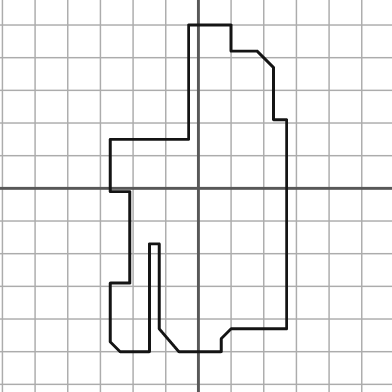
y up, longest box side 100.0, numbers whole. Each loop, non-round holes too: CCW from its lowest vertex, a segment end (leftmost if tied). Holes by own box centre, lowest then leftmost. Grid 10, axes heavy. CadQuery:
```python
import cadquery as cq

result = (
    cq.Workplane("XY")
    .moveTo(-24.0, -50.0)
    .lineTo(-15.0, -50.0)
    .lineTo(-15.0, -17.0)
    .lineTo(-12.0, -17.0)
    .lineTo(-12.0, -43.0)
    .lineTo(-6.0, -50.0)
    .lineTo(7.0, -50.0)
    .lineTo(7.0, -46.0)
    .lineTo(10.0, -43.0)
    .lineTo(27.0, -43.0)
    .lineTo(27.0, 21.0)
    .lineTo(23.0, 21.0)
    .lineTo(23.0, 37.0)
    .lineTo(18.0, 42.0)
    .lineTo(10.0, 42.0)
    .lineTo(10.0, 50.0)
    .lineTo(-3.0, 50.0)
    .lineTo(-3.0, 15.0)
    .lineTo(-27.0, 15.0)
    .lineTo(-27.0, -1.0)
    .lineTo(-21.0, -1.0)
    .lineTo(-21.0, -29.0)
    .lineTo(-27.0, -29.0)
    .lineTo(-27.0, -47.0)
    .close()
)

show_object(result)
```